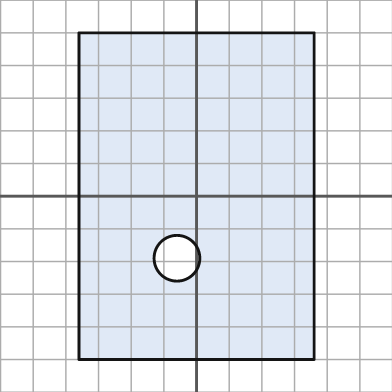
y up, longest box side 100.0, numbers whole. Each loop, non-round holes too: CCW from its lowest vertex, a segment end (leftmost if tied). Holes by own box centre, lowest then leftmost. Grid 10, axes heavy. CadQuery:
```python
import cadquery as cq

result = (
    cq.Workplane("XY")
    .moveTo(-36.0, -50.0)
    .lineTo(36.0, -50.0)
    .lineTo(36.0, 50.0)
    .lineTo(-36.0, 50.0)
    .close()
    .moveTo(-6.0, -19.0)
    .circle(7.0)
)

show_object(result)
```